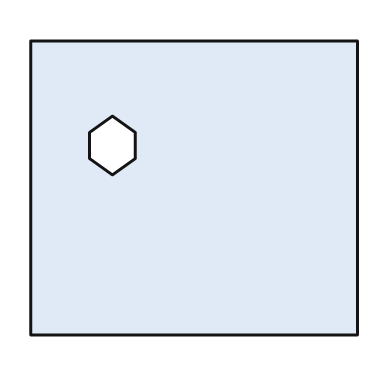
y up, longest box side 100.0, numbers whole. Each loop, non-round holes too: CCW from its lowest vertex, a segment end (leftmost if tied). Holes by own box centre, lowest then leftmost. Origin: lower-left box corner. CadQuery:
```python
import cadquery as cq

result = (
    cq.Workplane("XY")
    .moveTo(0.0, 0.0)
    .lineTo(100.0, 0.0)
    .lineTo(100.0, 90.0)
    .lineTo(0.0, 90.0)
    .close()
    .moveTo(25.0, 49.0)
    .lineTo(32.0, 54.0)
    .lineTo(32.0, 62.0)
    .lineTo(25.0, 67.0)
    .lineTo(18.0, 62.0)
    .lineTo(18.0, 54.0)
    .close()
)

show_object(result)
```